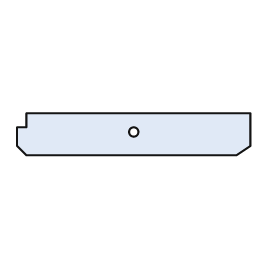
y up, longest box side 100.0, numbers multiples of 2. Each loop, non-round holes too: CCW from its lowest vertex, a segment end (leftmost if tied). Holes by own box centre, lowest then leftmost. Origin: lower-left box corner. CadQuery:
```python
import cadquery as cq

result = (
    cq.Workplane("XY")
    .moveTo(4.0, 0.0)
    .lineTo(94.0, 0.0)
    .lineTo(100.0, 4.0)
    .lineTo(100.0, 18.0)
    .lineTo(4.0, 18.0)
    .lineTo(4.0, 12.0)
    .lineTo(0.0, 12.0)
    .lineTo(0.0, 4.0)
    .close()
    .moveTo(50.0, 10.0)
    .circle(2.0)
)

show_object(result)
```